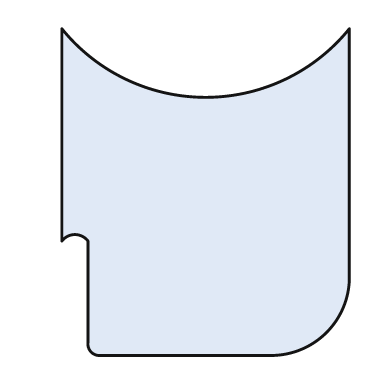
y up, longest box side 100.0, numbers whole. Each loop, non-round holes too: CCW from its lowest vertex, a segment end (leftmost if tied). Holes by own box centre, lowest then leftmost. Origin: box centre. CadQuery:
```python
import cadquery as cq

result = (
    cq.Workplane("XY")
    .moveTo(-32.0, -50.0)
    .lineTo(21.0, -50.0)
    .threePointArc((37.0, -43.0), (44.0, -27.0))
    .lineTo(44.0, 50.0)
    .threePointArc((0.0, 29.0), (-44.0, 50.0))
    .lineTo(-44.0, -15.0)
    .threePointArc((-40.0, -13.0), (-36.0, -15.0))
    .lineTo(-36.0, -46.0)
    .threePointArc((-35.0, -49.0), (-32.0, -50.0))
    .close()
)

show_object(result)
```